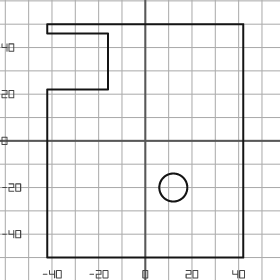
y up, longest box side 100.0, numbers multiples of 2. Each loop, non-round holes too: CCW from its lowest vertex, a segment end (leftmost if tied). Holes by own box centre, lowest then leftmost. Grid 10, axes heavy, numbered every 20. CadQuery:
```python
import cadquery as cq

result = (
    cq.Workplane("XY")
    .moveTo(-42.0, -50.0)
    .lineTo(42.0, -50.0)
    .lineTo(42.0, 50.0)
    .lineTo(-42.0, 50.0)
    .lineTo(-42.0, 46.0)
    .lineTo(-16.0, 46.0)
    .lineTo(-16.0, 22.0)
    .lineTo(-42.0, 22.0)
    .close()
    .moveTo(12.0, -20.0)
    .circle(6.0)
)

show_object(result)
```